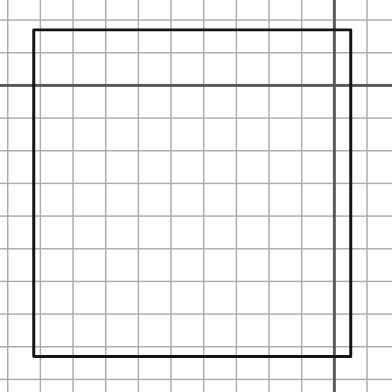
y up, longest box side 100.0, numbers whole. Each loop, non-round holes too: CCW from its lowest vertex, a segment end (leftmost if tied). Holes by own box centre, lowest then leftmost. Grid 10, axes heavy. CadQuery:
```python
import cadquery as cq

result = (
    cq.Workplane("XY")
    .moveTo(-92.0, -83.0)
    .lineTo(5.0, -83.0)
    .lineTo(5.0, 17.0)
    .lineTo(-92.0, 17.0)
    .close()
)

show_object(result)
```